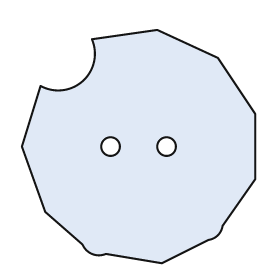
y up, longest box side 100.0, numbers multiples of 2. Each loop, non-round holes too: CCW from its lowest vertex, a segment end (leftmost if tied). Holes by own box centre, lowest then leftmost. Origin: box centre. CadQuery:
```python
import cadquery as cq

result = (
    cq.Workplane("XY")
    .moveTo(10.0, -50.0)
    .lineTo(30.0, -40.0)
    .threePointArc((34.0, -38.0), (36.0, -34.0))
    .lineTo(50.0, -14.0)
    .lineTo(50.0, 14.0)
    .lineTo(34.0, 38.0)
    .lineTo(8.0, 50.0)
    .lineTo(-20.0, 46.0)
    .threePointArc((-24.0, 28.0), (-42.0, 26.0))
    .lineTo(-50.0, 0.0)
    .lineTo(-40.0, -28.0)
    .lineTo(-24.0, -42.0)
    .threePointArc((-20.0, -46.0), (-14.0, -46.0))
    .close()
    .moveTo(-12.0, 0.0)
    .circle(4.0)
    .moveTo(12.0, 0.0)
    .circle(4.0)
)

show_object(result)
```